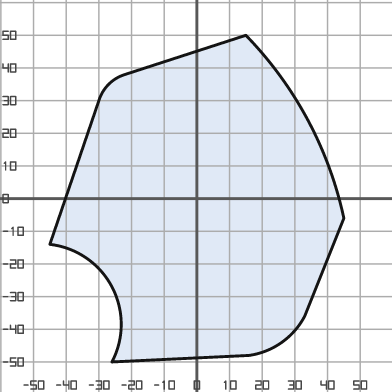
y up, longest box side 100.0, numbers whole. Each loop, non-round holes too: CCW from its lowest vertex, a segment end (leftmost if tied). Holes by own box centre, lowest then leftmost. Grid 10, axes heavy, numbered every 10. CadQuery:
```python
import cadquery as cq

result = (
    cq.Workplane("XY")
    .moveTo(-26.0, -50.0)
    .lineTo(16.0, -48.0)
    .threePointArc((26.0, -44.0), (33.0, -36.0))
    .lineTo(45.0, -6.0)
    .threePointArc((34.0, 24.0), (15.0, 50.0))
    .lineTo(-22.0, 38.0)
    .threePointArc((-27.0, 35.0), (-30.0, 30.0))
    .lineTo(-45.0, -14.0)
    .threePointArc((-26.0, -27.0), (-26.0, -50.0))
    .close()
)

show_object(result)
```